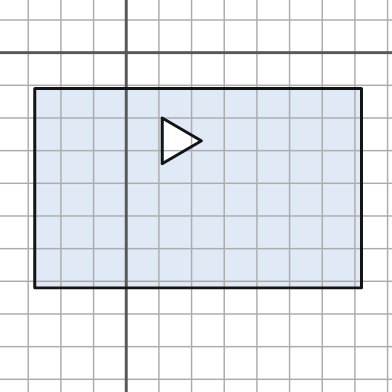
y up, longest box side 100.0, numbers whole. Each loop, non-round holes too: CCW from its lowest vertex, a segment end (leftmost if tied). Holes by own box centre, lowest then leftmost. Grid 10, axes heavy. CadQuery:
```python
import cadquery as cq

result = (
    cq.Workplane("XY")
    .moveTo(-28.0, -72.0)
    .lineTo(72.0, -72.0)
    .lineTo(72.0, -11.0)
    .lineTo(-28.0, -11.0)
    .close()
    .moveTo(11.0, -34.0)
    .lineTo(23.0, -27.0)
    .lineTo(11.0, -20.0)
    .close()
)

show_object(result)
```